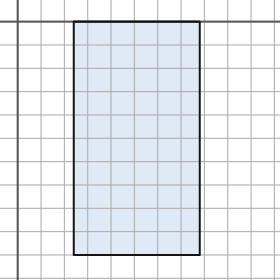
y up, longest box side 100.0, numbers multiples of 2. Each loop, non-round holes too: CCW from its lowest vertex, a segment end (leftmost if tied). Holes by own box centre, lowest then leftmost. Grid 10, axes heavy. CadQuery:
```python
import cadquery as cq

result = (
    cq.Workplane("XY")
    .moveTo(24.0, -100.0)
    .lineTo(78.0, -100.0)
    .lineTo(78.0, 0.0)
    .lineTo(24.0, 0.0)
    .close()
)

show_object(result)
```